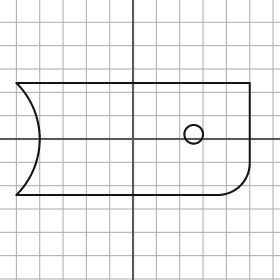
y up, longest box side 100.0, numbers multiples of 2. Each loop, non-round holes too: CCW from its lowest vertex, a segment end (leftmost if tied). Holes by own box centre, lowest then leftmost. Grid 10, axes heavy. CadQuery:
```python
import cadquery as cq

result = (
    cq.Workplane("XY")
    .moveTo(-50.0, -24.0)
    .lineTo(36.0, -24.0)
    .threePointArc((46.0, -20.0), (50.0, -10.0))
    .lineTo(50.0, 24.0)
    .lineTo(-50.0, 24.0)
    .threePointArc((-40.0, 0.0), (-50.0, -24.0))
    .close()
    .moveTo(26.0, 2.0)
    .circle(4.0)
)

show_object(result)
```